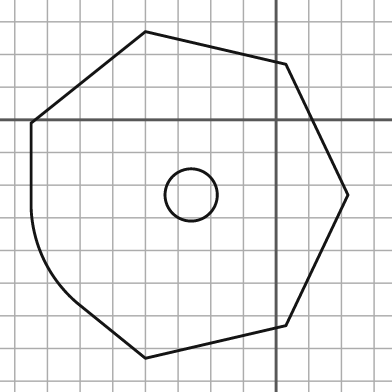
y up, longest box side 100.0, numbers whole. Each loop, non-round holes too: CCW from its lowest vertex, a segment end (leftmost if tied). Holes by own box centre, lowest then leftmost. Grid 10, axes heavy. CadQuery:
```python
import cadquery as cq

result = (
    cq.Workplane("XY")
    .moveTo(-40.0, -73.0)
    .lineTo(3.0, -63.0)
    .lineTo(22.0, -23.0)
    .lineTo(3.0, 17.0)
    .lineTo(-40.0, 27.0)
    .lineTo(-75.0, -1.0)
    .lineTo(-75.0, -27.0)
    .threePointArc((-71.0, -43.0), (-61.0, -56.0))
    .close()
    .moveTo(-26.0, -23.0)
    .circle(8.0)
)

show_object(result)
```